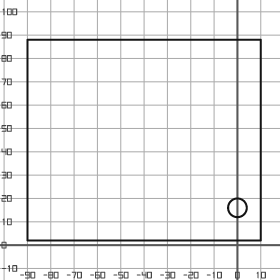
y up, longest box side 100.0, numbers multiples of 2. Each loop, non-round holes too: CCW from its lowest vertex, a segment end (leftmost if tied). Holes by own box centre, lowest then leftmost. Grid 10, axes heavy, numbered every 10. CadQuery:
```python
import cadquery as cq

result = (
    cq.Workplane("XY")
    .moveTo(-90.0, 2.0)
    .lineTo(10.0, 2.0)
    .lineTo(10.0, 88.0)
    .lineTo(-90.0, 88.0)
    .close()
    .moveTo(0.0, 16.0)
    .circle(4.0)
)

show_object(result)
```